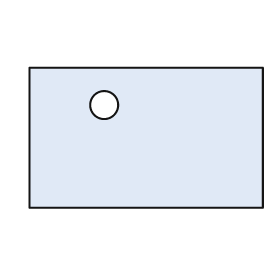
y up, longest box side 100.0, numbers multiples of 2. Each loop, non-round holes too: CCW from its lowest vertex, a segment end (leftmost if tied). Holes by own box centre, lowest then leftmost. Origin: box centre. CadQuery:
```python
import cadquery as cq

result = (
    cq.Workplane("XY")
    .moveTo(-50.0, -30.0)
    .lineTo(50.0, -30.0)
    .lineTo(50.0, 30.0)
    .lineTo(-50.0, 30.0)
    .close()
    .moveTo(-18.0, 14.0)
    .circle(6.0)
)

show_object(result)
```